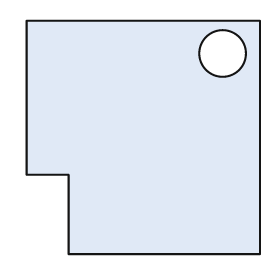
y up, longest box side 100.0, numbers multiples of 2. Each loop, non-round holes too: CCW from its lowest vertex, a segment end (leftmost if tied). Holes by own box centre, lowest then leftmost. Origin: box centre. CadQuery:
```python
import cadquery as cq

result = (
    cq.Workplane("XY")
    .moveTo(-32.0, -50.0)
    .lineTo(50.0, -50.0)
    .lineTo(50.0, 50.0)
    .lineTo(-50.0, 50.0)
    .lineTo(-50.0, -16.0)
    .lineTo(-32.0, -16.0)
    .close()
    .moveTo(34.0, 36.0)
    .circle(10.0)
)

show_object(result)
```